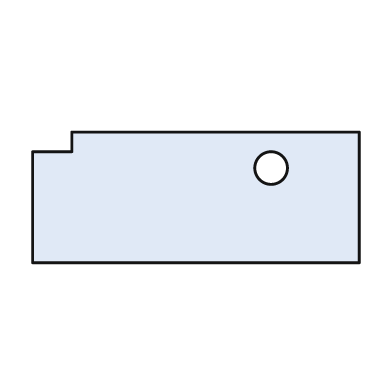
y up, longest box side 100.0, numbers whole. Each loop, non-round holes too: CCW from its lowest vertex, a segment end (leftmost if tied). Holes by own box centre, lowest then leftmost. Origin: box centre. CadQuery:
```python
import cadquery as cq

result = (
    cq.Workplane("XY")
    .moveTo(-50.0, -20.0)
    .lineTo(50.0, -20.0)
    .lineTo(50.0, 20.0)
    .lineTo(-38.0, 20.0)
    .lineTo(-38.0, 14.0)
    .lineTo(-50.0, 14.0)
    .close()
    .moveTo(23.0, 9.0)
    .circle(5.0)
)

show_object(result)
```